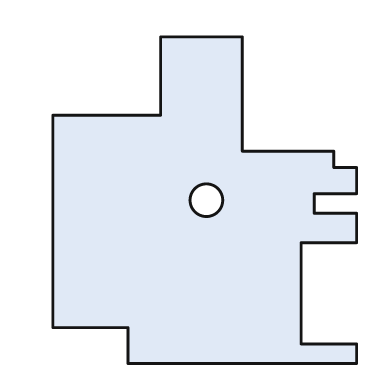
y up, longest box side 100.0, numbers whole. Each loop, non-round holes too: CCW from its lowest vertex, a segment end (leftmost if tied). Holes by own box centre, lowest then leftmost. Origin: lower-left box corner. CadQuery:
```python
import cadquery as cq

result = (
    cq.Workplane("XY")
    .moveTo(23.0, 0.0)
    .lineTo(93.0, 0.0)
    .lineTo(93.0, 6.0)
    .lineTo(76.0, 6.0)
    .lineTo(76.0, 37.0)
    .lineTo(93.0, 37.0)
    .lineTo(93.0, 46.0)
    .lineTo(80.0, 46.0)
    .lineTo(80.0, 52.0)
    .lineTo(93.0, 52.0)
    .lineTo(93.0, 60.0)
    .lineTo(86.0, 60.0)
    .lineTo(86.0, 65.0)
    .lineTo(58.0, 65.0)
    .lineTo(58.0, 100.0)
    .lineTo(33.0, 100.0)
    .lineTo(33.0, 76.0)
    .lineTo(0.0, 76.0)
    .lineTo(0.0, 11.0)
    .lineTo(23.0, 11.0)
    .close()
    .moveTo(47.0, 50.0)
    .circle(5.0)
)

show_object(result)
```